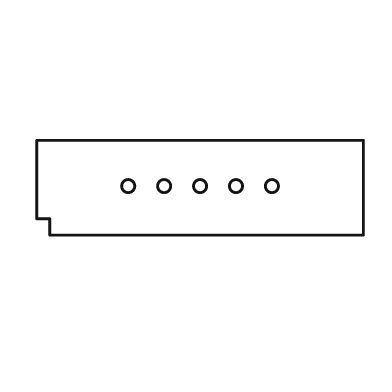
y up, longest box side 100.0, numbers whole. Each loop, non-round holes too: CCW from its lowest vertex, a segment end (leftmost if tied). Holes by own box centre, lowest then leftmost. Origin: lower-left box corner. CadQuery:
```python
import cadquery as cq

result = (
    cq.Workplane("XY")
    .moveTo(4.0, 0.0)
    .lineTo(100.0, 0.0)
    .lineTo(100.0, 29.0)
    .lineTo(0.0, 29.0)
    .lineTo(0.0, 5.0)
    .lineTo(4.0, 5.0)
    .close()
    .moveTo(28.0, 15.0)
    .circle(2.0)
    .moveTo(39.0, 15.0)
    .circle(2.0)
    .moveTo(50.0, 15.0)
    .circle(2.0)
    .moveTo(61.0, 15.0)
    .circle(2.0)
    .moveTo(72.0, 15.0)
    .circle(2.0)
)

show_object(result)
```